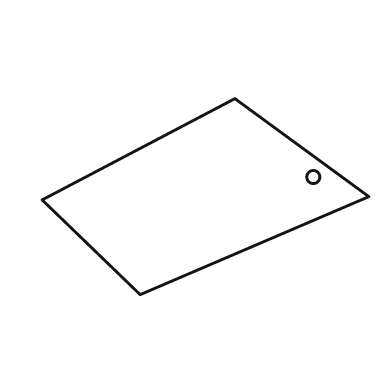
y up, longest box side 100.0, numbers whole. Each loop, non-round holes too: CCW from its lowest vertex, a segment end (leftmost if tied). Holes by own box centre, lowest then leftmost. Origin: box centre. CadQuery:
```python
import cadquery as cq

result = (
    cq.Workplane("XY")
    .moveTo(-20.0, -30.0)
    .lineTo(50.0, 0.0)
    .lineTo(9.0, 30.0)
    .lineTo(-50.0, -1.0)
    .close()
    .moveTo(33.0, 6.0)
    .circle(2.0)
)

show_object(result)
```